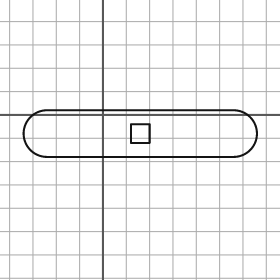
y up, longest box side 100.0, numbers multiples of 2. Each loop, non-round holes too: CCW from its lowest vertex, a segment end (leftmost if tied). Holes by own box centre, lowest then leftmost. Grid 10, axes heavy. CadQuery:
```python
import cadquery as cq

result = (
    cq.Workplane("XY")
    .moveTo(-24.0, -18.0)
    .lineTo(56.0, -18.0)
    .threePointArc((66.0, -8.0), (56.0, 2.0))
    .lineTo(-24.0, 2.0)
    .threePointArc((-34.0, -8.0), (-24.0, -18.0))
    .close()
    .moveTo(12.0, -12.0)
    .lineTo(20.0, -12.0)
    .lineTo(20.0, -4.0)
    .lineTo(12.0, -4.0)
    .close()
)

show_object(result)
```